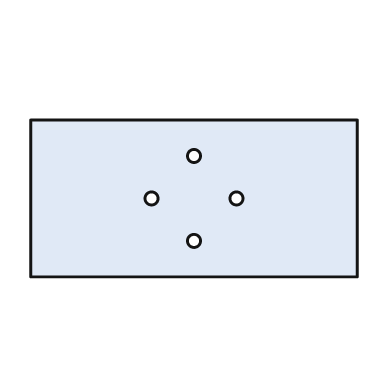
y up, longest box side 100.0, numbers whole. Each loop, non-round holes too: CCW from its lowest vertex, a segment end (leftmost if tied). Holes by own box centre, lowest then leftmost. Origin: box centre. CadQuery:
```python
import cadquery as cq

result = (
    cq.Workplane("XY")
    .moveTo(-50.0, -24.0)
    .lineTo(50.0, -24.0)
    .lineTo(50.0, 24.0)
    .lineTo(-50.0, 24.0)
    .close()
    .moveTo(0.0, -13.0)
    .circle(2.0)
    .moveTo(-13.0, 0.0)
    .circle(2.0)
    .moveTo(13.0, 0.0)
    .circle(2.0)
    .moveTo(0.0, 13.0)
    .circle(2.0)
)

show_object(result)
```